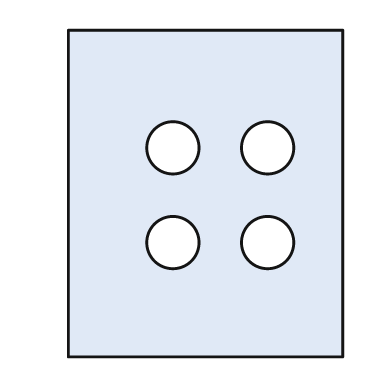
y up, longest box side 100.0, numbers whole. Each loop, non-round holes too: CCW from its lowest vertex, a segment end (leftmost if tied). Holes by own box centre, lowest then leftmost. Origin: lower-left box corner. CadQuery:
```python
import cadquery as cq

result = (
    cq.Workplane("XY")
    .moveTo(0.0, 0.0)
    .lineTo(84.0, 0.0)
    .lineTo(84.0, 100.0)
    .lineTo(0.0, 100.0)
    .close()
    .moveTo(32.0, 35.0)
    .circle(8.0)
    .moveTo(61.0, 35.0)
    .circle(8.0)
    .moveTo(32.0, 64.0)
    .circle(8.0)
    .moveTo(61.0, 64.0)
    .circle(8.0)
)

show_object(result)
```